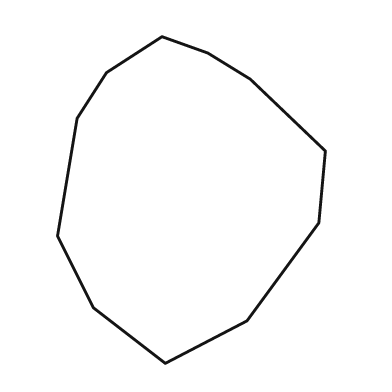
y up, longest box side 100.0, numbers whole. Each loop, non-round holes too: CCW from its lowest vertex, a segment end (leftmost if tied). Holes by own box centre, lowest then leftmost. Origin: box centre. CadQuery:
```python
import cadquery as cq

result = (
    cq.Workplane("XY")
    .moveTo(-8.0, -50.0)
    .lineTo(17.0, -37.0)
    .lineTo(39.0, -7.0)
    .lineTo(41.0, 15.0)
    .lineTo(18.0, 37.0)
    .lineTo(5.0, 45.0)
    .lineTo(-9.0, 50.0)
    .lineTo(-26.0, 39.0)
    .lineTo(-35.0, 25.0)
    .lineTo(-41.0, -11.0)
    .lineTo(-30.0, -33.0)
    .close()
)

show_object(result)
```